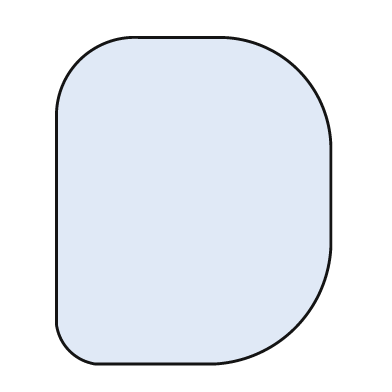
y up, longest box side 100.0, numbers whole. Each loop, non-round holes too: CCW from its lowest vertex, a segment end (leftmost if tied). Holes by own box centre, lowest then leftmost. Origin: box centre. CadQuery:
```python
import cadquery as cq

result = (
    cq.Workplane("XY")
    .moveTo(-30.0, -50.0)
    .lineTo(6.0, -50.0)
    .threePointArc((31.0, -39.0), (42.0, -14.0))
    .lineTo(42.0, 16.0)
    .threePointArc((32.0, 40.0), (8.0, 50.0))
    .lineTo(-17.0, 50.0)
    .threePointArc((-35.0, 43.0), (-42.0, 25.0))
    .lineTo(-42.0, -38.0)
    .threePointArc((-38.0, -46.0), (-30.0, -50.0))
    .close()
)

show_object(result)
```